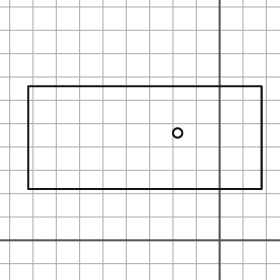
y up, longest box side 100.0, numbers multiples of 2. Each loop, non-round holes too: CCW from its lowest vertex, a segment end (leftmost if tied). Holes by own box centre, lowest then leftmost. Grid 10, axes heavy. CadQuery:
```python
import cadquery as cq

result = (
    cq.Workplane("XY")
    .moveTo(-82.0, 22.0)
    .lineTo(18.0, 22.0)
    .lineTo(18.0, 66.0)
    .lineTo(-82.0, 66.0)
    .close()
    .moveTo(-18.0, 46.0)
    .circle(2.0)
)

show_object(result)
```